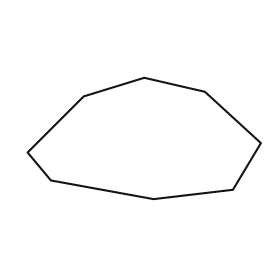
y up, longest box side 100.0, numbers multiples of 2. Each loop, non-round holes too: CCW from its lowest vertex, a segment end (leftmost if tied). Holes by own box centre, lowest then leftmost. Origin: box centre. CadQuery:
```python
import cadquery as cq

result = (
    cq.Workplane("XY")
    .moveTo(4.0, -26.0)
    .lineTo(38.0, -22.0)
    .lineTo(50.0, -2.0)
    .lineTo(26.0, 20.0)
    .lineTo(0.0, 26.0)
    .lineTo(-26.0, 18.0)
    .lineTo(-50.0, -6.0)
    .lineTo(-40.0, -18.0)
    .close()
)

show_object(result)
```